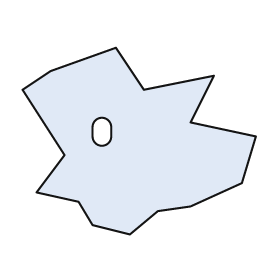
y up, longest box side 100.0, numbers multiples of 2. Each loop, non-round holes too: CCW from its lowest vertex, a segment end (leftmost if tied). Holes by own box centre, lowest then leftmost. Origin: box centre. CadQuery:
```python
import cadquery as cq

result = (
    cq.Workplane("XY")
    .moveTo(-4.0, -40.0)
    .lineTo(8.0, -30.0)
    .lineTo(22.0, -28.0)
    .lineTo(44.0, -18.0)
    .lineTo(50.0, 2.0)
    .lineTo(22.0, 8.0)
    .lineTo(32.0, 28.0)
    .lineTo(2.0, 22.0)
    .lineTo(-10.0, 40.0)
    .lineTo(-38.0, 30.0)
    .lineTo(-50.0, 22.0)
    .lineTo(-32.0, -6.0)
    .lineTo(-44.0, -22.0)
    .lineTo(-26.0, -26.0)
    .lineTo(-20.0, -36.0)
    .close()
    .moveTo(-20.0, 2.0)
    .threePointArc((-16.0, -2.0), (-12.0, 2.0))
    .lineTo(-12.0, 6.0)
    .threePointArc((-16.0, 10.0), (-20.0, 6.0))
    .close()
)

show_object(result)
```